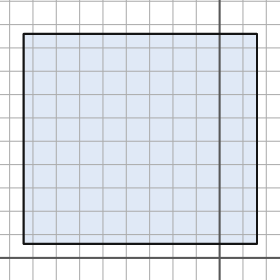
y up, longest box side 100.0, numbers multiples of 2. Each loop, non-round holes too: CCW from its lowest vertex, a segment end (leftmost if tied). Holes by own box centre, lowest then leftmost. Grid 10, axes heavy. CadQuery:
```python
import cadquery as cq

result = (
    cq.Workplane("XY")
    .moveTo(-84.0, 6.0)
    .lineTo(16.0, 6.0)
    .lineTo(16.0, 96.0)
    .lineTo(-84.0, 96.0)
    .close()
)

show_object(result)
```